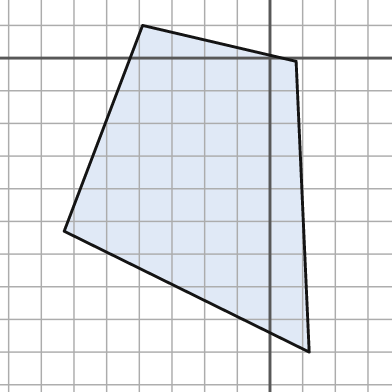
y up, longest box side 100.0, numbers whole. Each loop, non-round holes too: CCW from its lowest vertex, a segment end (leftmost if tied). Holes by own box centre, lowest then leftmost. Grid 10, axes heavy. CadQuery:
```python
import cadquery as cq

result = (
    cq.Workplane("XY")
    .moveTo(12.0, -90.0)
    .lineTo(8.0, -1.0)
    .lineTo(-39.0, 10.0)
    .lineTo(-63.0, -53.0)
    .close()
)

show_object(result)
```